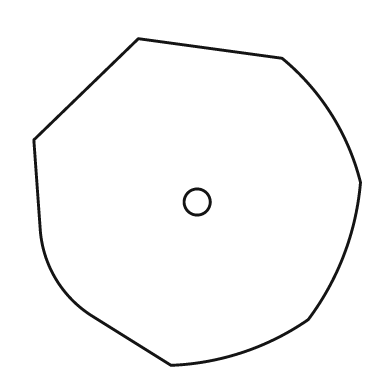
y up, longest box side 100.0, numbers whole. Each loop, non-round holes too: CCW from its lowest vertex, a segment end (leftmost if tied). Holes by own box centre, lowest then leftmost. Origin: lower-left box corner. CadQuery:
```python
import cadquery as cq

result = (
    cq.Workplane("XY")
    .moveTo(42.0, 0.0)
    .threePointArc((64.0, 4.0), (84.0, 14.0))
    .threePointArc((95.0, 34.0), (100.0, 56.0))
    .threePointArc((91.0, 77.0), (76.0, 94.0))
    .lineTo(32.0, 100.0)
    .lineTo(0.0, 69.0)
    .lineTo(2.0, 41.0)
    .threePointArc((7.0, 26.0), (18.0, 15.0))
    .close()
    .moveTo(50.0, 50.0)
    .circle(4.0)
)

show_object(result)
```